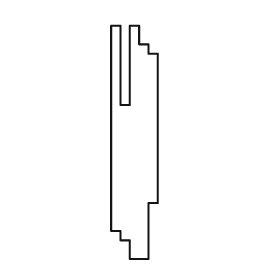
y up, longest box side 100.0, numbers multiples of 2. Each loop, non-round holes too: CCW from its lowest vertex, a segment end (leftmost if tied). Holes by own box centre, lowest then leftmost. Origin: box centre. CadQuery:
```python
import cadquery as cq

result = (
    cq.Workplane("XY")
    .moveTo(-2.0, -50.0)
    .lineTo(6.0, -50.0)
    .lineTo(6.0, -26.0)
    .lineTo(10.0, -26.0)
    .lineTo(10.0, 38.0)
    .lineTo(6.0, 38.0)
    .lineTo(6.0, 42.0)
    .lineTo(2.0, 42.0)
    .lineTo(2.0, 50.0)
    .lineTo(-2.0, 50.0)
    .lineTo(-2.0, 16.0)
    .lineTo(-6.0, 16.0)
    .lineTo(-6.0, 50.0)
    .lineTo(-10.0, 50.0)
    .lineTo(-10.0, -38.0)
    .lineTo(-6.0, -38.0)
    .lineTo(-6.0, -42.0)
    .lineTo(-2.0, -42.0)
    .close()
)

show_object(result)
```